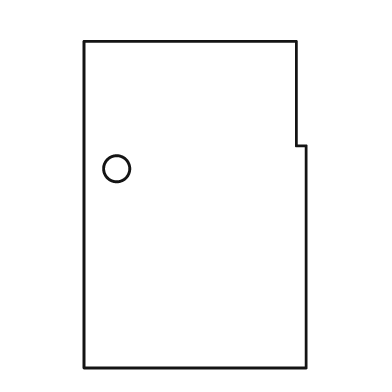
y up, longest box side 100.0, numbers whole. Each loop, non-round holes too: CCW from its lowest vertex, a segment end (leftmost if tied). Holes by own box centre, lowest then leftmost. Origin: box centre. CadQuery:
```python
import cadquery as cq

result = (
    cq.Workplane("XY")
    .moveTo(-34.0, -50.0)
    .lineTo(34.0, -50.0)
    .lineTo(34.0, 18.0)
    .lineTo(31.0, 18.0)
    .lineTo(31.0, 50.0)
    .lineTo(-34.0, 50.0)
    .close()
    .moveTo(-24.0, 11.0)
    .circle(4.0)
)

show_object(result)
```